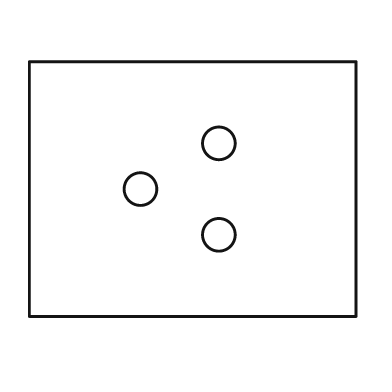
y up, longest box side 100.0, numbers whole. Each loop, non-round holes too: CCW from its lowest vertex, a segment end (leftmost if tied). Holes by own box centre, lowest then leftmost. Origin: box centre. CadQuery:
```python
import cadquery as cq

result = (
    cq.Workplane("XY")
    .moveTo(-50.0, -39.0)
    .lineTo(50.0, -39.0)
    .lineTo(50.0, 39.0)
    .lineTo(-50.0, 39.0)
    .close()
    .moveTo(8.0, -14.0)
    .circle(5.0)
    .moveTo(-16.0, 0.0)
    .circle(5.0)
    .moveTo(8.0, 14.0)
    .circle(5.0)
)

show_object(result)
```